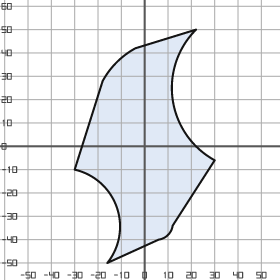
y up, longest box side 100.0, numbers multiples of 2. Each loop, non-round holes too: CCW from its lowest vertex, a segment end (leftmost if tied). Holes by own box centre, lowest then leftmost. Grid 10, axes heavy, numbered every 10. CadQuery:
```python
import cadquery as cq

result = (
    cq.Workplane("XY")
    .moveTo(-16.0, -50.0)
    .lineTo(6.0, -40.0)
    .threePointArc((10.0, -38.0), (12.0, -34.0))
    .lineTo(30.0, -6.0)
    .threePointArc((12.0, 20.0), (22.0, 50.0))
    .lineTo(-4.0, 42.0)
    .threePointArc((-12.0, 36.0), (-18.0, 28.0))
    .lineTo(-30.0, -10.0)
    .threePointArc((-12.0, -26.0), (-16.0, -50.0))
    .close()
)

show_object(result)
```